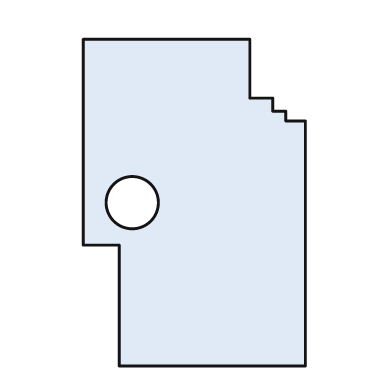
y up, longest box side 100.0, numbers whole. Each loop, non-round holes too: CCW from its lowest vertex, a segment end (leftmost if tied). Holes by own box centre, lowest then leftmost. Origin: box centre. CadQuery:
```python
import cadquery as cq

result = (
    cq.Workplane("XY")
    .moveTo(-23.0, -50.0)
    .lineTo(34.0, -50.0)
    .lineTo(34.0, 25.0)
    .lineTo(28.0, 25.0)
    .lineTo(28.0, 28.0)
    .lineTo(24.0, 28.0)
    .lineTo(24.0, 32.0)
    .lineTo(17.0, 32.0)
    .lineTo(17.0, 50.0)
    .lineTo(-34.0, 50.0)
    .lineTo(-34.0, -13.0)
    .lineTo(-23.0, -13.0)
    .close()
    .moveTo(-19.0, 0.0)
    .circle(8.0)
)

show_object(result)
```